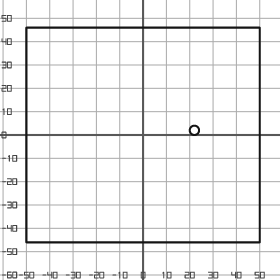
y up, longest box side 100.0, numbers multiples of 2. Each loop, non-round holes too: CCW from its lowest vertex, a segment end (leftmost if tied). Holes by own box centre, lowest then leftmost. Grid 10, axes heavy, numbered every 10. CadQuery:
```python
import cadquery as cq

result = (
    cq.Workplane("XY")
    .moveTo(-50.0, -46.0)
    .lineTo(50.0, -46.0)
    .lineTo(50.0, 46.0)
    .lineTo(-50.0, 46.0)
    .close()
    .moveTo(22.0, 2.0)
    .circle(2.0)
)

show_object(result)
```